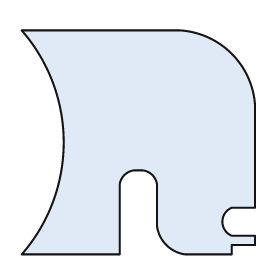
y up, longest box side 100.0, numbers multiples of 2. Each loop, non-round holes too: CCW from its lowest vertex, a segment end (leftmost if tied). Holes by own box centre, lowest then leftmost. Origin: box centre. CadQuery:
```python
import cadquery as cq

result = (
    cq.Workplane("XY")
    .moveTo(-50.0, -48.0)
    .lineTo(-8.0, -48.0)
    .lineTo(-8.0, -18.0)
    .threePointArc((-6.0, -14.0), (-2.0, -12.0))
    .lineTo(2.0, -12.0)
    .threePointArc((6.0, -14.0), (8.0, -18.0))
    .lineTo(8.0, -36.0)
    .threePointArc((12.0, -44.0), (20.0, -48.0))
    .lineTo(40.0, -48.0)
    .lineTo(40.0, -44.0)
    .lineTo(50.0, -44.0)
    .lineTo(50.0, -40.0)
    .lineTo(40.0, -40.0)
    .threePointArc((36.0, -34.0), (40.0, -28.0))
    .lineTo(50.0, -28.0)
    .lineTo(50.0, 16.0)
    .threePointArc((40.0, 38.0), (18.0, 48.0))
    .lineTo(-50.0, 48.0)
    .threePointArc((-32.0, 0.0), (-50.0, -48.0))
    .close()
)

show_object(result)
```